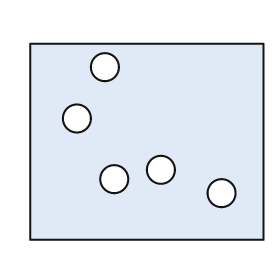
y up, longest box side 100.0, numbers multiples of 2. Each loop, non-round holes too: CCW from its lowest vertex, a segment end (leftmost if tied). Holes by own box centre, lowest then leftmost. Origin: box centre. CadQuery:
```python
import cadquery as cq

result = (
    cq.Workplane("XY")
    .moveTo(-50.0, -42.0)
    .lineTo(50.0, -42.0)
    .lineTo(50.0, 42.0)
    .lineTo(-50.0, 42.0)
    .close()
    .moveTo(32.0, -22.0)
    .circle(6.0)
    .moveTo(-14.0, -16.0)
    .circle(6.0)
    .moveTo(6.0, -12.0)
    .circle(6.0)
    .moveTo(-30.0, 10.0)
    .circle(6.0)
    .moveTo(-18.0, 32.0)
    .circle(6.0)
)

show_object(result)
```